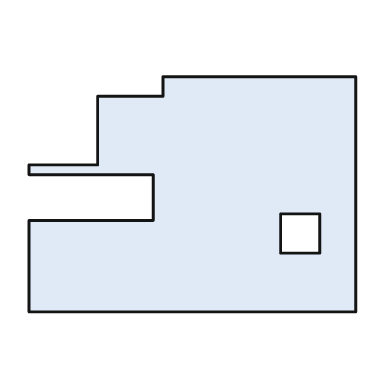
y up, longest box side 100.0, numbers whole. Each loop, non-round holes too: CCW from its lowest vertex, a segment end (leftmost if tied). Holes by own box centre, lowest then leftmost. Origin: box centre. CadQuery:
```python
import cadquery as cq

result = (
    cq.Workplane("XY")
    .moveTo(-50.0, -36.0)
    .lineTo(50.0, -36.0)
    .lineTo(50.0, 36.0)
    .lineTo(-9.0, 36.0)
    .lineTo(-9.0, 30.0)
    .lineTo(-29.0, 30.0)
    .lineTo(-29.0, 9.0)
    .lineTo(-50.0, 9.0)
    .lineTo(-50.0, 6.0)
    .lineTo(-12.0, 6.0)
    .lineTo(-12.0, -8.0)
    .lineTo(-50.0, -8.0)
    .close()
    .moveTo(27.0, -18.0)
    .lineTo(39.0, -18.0)
    .lineTo(39.0, -6.0)
    .lineTo(27.0, -6.0)
    .close()
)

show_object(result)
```